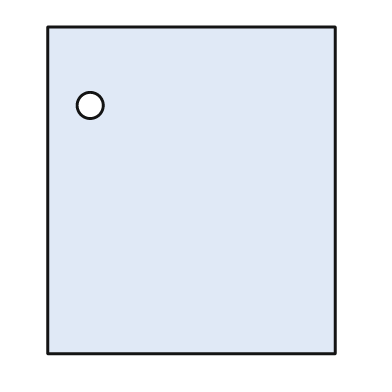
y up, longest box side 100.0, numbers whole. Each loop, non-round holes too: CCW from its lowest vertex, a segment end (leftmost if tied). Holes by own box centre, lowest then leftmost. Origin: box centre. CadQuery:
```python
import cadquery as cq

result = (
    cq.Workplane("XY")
    .moveTo(-44.0, -50.0)
    .lineTo(44.0, -50.0)
    .lineTo(44.0, 50.0)
    .lineTo(-44.0, 50.0)
    .close()
    .moveTo(-31.0, 26.0)
    .circle(4.0)
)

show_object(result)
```